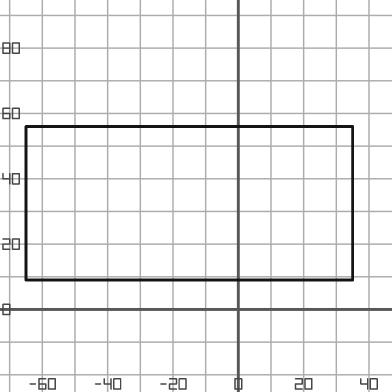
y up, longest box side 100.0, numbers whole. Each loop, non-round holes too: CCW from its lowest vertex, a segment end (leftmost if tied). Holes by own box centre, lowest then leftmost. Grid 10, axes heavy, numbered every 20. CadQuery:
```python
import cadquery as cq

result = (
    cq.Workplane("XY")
    .moveTo(-65.0, 9.0)
    .lineTo(35.0, 9.0)
    .lineTo(35.0, 56.0)
    .lineTo(-65.0, 56.0)
    .close()
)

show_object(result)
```